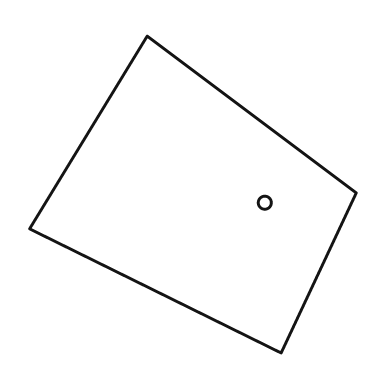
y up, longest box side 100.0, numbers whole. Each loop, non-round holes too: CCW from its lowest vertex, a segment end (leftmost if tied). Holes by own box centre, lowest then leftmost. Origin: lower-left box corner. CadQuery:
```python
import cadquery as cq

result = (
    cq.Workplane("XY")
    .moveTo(77.0, 0.0)
    .lineTo(100.0, 49.0)
    .lineTo(36.0, 97.0)
    .lineTo(0.0, 38.0)
    .close()
    .moveTo(72.0, 46.0)
    .circle(2.0)
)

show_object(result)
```